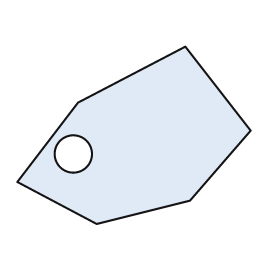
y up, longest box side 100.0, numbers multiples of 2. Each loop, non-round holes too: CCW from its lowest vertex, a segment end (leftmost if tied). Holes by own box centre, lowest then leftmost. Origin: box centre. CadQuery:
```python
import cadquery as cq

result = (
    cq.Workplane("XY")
    .moveTo(-16.0, -38.0)
    .lineTo(24.0, -28.0)
    .lineTo(50.0, 2.0)
    .lineTo(22.0, 38.0)
    .lineTo(-24.0, 14.0)
    .lineTo(-50.0, -20.0)
    .close()
    .moveTo(-26.0, -8.0)
    .circle(8.0)
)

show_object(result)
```